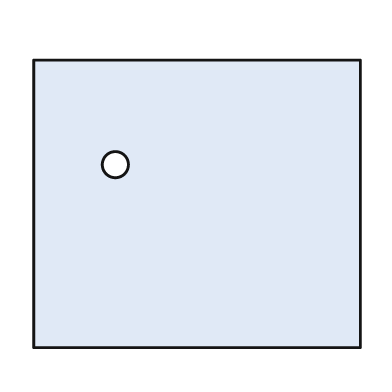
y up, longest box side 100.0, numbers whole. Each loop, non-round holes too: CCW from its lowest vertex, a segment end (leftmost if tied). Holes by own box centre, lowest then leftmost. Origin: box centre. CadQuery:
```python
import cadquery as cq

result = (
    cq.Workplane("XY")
    .moveTo(-50.0, -44.0)
    .lineTo(50.0, -44.0)
    .lineTo(50.0, 44.0)
    .lineTo(-50.0, 44.0)
    .close()
    .moveTo(-25.0, 12.0)
    .circle(4.0)
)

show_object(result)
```